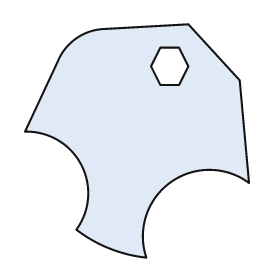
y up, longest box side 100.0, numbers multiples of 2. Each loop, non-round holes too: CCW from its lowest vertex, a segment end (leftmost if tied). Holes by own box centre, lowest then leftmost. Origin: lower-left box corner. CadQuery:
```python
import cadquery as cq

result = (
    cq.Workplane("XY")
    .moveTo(52.0, 0.0)
    .threePointArc((62.0, 32.0), (96.0, 32.0))
    .lineTo(92.0, 76.0)
    .lineTo(70.0, 100.0)
    .lineTo(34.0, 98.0)
    .threePointArc((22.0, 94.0), (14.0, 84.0))
    .lineTo(0.0, 54.0)
    .threePointArc((24.0, 40.0), (22.0, 12.0))
    .threePointArc((36.0, 4.0), (52.0, 0.0))
    .close()
    .moveTo(58.0, 74.0)
    .lineTo(66.0, 74.0)
    .lineTo(70.0, 82.0)
    .lineTo(66.0, 90.0)
    .lineTo(58.0, 90.0)
    .lineTo(54.0, 82.0)
    .close()
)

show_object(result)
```